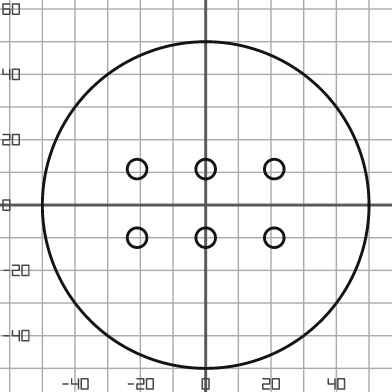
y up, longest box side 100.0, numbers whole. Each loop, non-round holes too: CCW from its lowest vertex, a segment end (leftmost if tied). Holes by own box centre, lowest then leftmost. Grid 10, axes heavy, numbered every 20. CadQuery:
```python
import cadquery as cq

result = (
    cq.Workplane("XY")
    .moveTo(0.0, 0.0)
    .circle(50.0)
    .moveTo(-21.0, -10.0)
    .circle(3.0)
    .moveTo(0.0, -10.0)
    .circle(3.0)
    .moveTo(21.0, -10.0)
    .circle(3.0)
    .moveTo(-21.0, 11.0)
    .circle(3.0)
    .moveTo(0.0, 11.0)
    .circle(3.0)
    .moveTo(21.0, 11.0)
    .circle(3.0)
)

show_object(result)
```